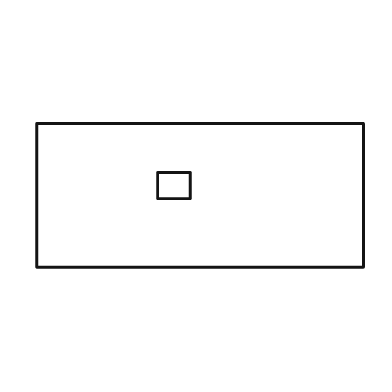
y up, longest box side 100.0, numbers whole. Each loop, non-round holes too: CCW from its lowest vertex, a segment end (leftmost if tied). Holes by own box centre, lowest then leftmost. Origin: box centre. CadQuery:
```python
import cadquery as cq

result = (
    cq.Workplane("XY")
    .moveTo(-50.0, -22.0)
    .lineTo(50.0, -22.0)
    .lineTo(50.0, 22.0)
    .lineTo(-50.0, 22.0)
    .close()
    .moveTo(-13.0, -1.0)
    .lineTo(-3.0, -1.0)
    .lineTo(-3.0, 7.0)
    .lineTo(-13.0, 7.0)
    .close()
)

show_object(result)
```